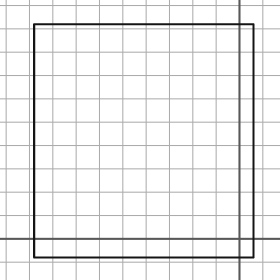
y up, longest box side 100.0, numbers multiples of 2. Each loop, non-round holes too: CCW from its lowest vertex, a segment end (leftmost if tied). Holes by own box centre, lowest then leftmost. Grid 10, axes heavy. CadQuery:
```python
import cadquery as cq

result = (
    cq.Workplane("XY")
    .moveTo(-88.0, -8.0)
    .lineTo(6.0, -8.0)
    .lineTo(6.0, 92.0)
    .lineTo(-88.0, 92.0)
    .close()
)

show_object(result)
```